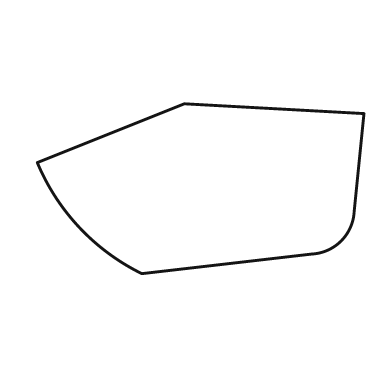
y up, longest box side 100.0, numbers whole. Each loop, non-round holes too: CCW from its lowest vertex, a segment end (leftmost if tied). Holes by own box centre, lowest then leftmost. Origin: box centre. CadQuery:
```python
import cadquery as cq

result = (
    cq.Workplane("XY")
    .moveTo(-18.0, -26.0)
    .lineTo(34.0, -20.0)
    .threePointArc((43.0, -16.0), (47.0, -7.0))
    .lineTo(50.0, 23.0)
    .lineTo(-5.0, 26.0)
    .lineTo(-50.0, 8.0)
    .threePointArc((-37.0, -12.0), (-18.0, -26.0))
    .close()
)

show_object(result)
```